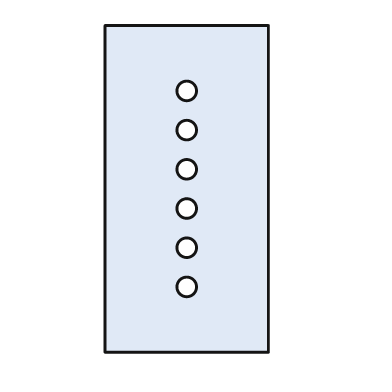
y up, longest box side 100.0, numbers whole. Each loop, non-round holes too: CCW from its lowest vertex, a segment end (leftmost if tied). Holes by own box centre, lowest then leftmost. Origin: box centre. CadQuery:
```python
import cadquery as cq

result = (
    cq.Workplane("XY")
    .moveTo(-25.0, -50.0)
    .lineTo(25.0, -50.0)
    .lineTo(25.0, 50.0)
    .lineTo(-25.0, 50.0)
    .close()
    .moveTo(0.0, -30.0)
    .circle(3.0)
    .moveTo(0.0, -18.0)
    .circle(3.0)
    .moveTo(0.0, -6.0)
    .circle(3.0)
    .moveTo(0.0, 6.0)
    .circle(3.0)
    .moveTo(0.0, 18.0)
    .circle(3.0)
    .moveTo(0.0, 30.0)
    .circle(3.0)
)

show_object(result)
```